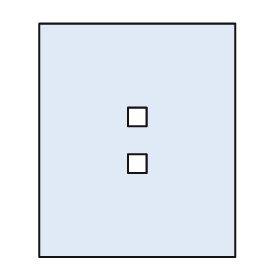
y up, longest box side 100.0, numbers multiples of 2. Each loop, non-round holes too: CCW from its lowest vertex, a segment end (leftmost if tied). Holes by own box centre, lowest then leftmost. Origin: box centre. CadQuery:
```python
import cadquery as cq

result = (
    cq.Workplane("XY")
    .moveTo(-42.0, -50.0)
    .lineTo(42.0, -50.0)
    .lineTo(42.0, 50.0)
    .lineTo(-42.0, 50.0)
    .close()
    .moveTo(-4.0, -14.0)
    .lineTo(4.0, -14.0)
    .lineTo(4.0, -6.0)
    .lineTo(-4.0, -6.0)
    .close()
    .moveTo(-4.0, 6.0)
    .lineTo(4.0, 6.0)
    .lineTo(4.0, 14.0)
    .lineTo(-4.0, 14.0)
    .close()
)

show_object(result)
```